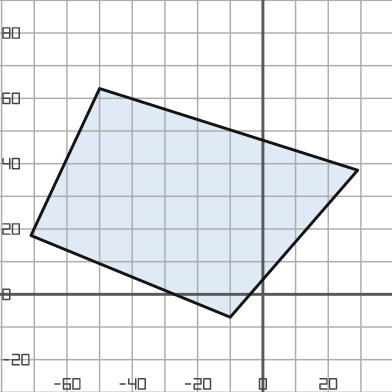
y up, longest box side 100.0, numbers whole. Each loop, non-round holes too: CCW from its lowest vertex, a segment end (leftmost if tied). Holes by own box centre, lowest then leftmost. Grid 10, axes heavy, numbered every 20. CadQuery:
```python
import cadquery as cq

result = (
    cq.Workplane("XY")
    .moveTo(-10.0, -7.0)
    .lineTo(29.0, 38.0)
    .lineTo(-50.0, 63.0)
    .lineTo(-71.0, 18.0)
    .close()
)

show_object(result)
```